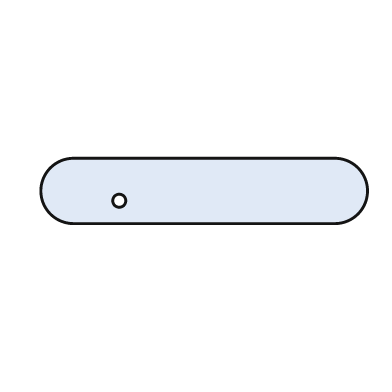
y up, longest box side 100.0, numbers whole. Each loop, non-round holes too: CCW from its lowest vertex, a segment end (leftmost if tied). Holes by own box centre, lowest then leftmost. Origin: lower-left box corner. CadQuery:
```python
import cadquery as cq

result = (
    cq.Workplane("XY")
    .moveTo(10.0, 0.0)
    .lineTo(90.0, 0.0)
    .threePointArc((100.0, 10.0), (90.0, 20.0))
    .lineTo(10.0, 20.0)
    .threePointArc((0.0, 10.0), (10.0, 0.0))
    .close()
    .moveTo(24.0, 7.0)
    .circle(2.0)
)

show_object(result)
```